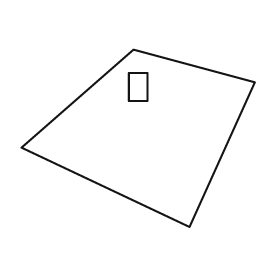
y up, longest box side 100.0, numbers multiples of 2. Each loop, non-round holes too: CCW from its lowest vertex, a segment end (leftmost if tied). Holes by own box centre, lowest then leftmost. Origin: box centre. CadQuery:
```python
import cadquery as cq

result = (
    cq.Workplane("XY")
    .moveTo(22.0, -38.0)
    .lineTo(50.0, 24.0)
    .lineTo(-2.0, 38.0)
    .lineTo(-50.0, -4.0)
    .close()
    .moveTo(-4.0, 16.0)
    .lineTo(4.0, 16.0)
    .lineTo(4.0, 28.0)
    .lineTo(-4.0, 28.0)
    .close()
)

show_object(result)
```